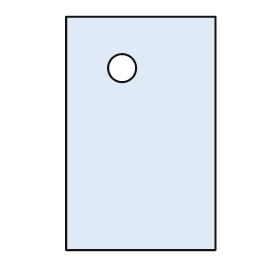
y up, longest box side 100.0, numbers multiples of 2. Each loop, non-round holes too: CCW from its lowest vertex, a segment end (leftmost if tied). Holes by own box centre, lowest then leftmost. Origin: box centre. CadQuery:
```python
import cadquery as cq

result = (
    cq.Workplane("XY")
    .moveTo(-32.0, -50.0)
    .lineTo(32.0, -50.0)
    .lineTo(32.0, 50.0)
    .lineTo(-32.0, 50.0)
    .close()
    .moveTo(-8.0, 28.0)
    .circle(6.0)
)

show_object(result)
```